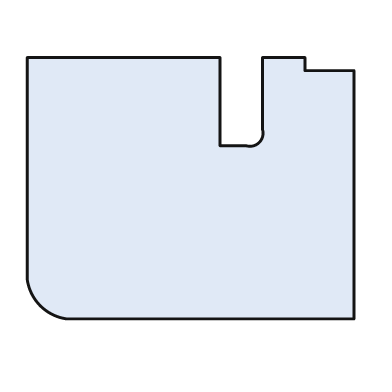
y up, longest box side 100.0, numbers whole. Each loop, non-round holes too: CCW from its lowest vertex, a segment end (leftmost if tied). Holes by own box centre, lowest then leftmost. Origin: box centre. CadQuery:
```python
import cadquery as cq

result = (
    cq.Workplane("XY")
    .moveTo(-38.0, -40.0)
    .lineTo(50.0, -40.0)
    .lineTo(50.0, 36.0)
    .lineTo(35.0, 36.0)
    .lineTo(35.0, 40.0)
    .lineTo(22.0, 40.0)
    .lineTo(22.0, 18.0)
    .threePointArc((21.0, 14.0), (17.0, 13.0))
    .lineTo(9.0, 13.0)
    .lineTo(9.0, 40.0)
    .lineTo(-50.0, 40.0)
    .lineTo(-50.0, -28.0)
    .threePointArc((-46.0, -36.0), (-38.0, -40.0))
    .close()
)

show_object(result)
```